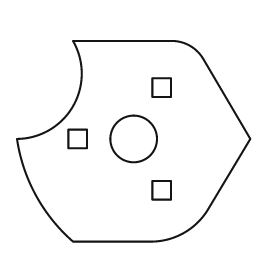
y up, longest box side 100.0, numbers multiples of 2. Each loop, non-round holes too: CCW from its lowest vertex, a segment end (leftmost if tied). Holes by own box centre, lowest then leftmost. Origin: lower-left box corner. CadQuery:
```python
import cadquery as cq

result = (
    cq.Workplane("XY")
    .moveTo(24.0, 0.0)
    .lineTo(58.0, 0.0)
    .threePointArc((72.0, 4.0), (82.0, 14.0))
    .lineTo(100.0, 44.0)
    .lineTo(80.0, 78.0)
    .threePointArc((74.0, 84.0), (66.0, 86.0))
    .lineTo(24.0, 86.0)
    .threePointArc((24.0, 58.0), (0.0, 44.0))
    .threePointArc((8.0, 20.0), (24.0, 0.0))
    .close()
    .moveTo(58.0, 18.0)
    .lineTo(66.0, 18.0)
    .lineTo(66.0, 26.0)
    .lineTo(58.0, 26.0)
    .close()
    .moveTo(22.0, 40.0)
    .lineTo(30.0, 40.0)
    .lineTo(30.0, 48.0)
    .lineTo(22.0, 48.0)
    .close()
    .moveTo(50.0, 44.0)
    .circle(10.0)
    .moveTo(58.0, 62.0)
    .lineTo(66.0, 62.0)
    .lineTo(66.0, 70.0)
    .lineTo(58.0, 70.0)
    .close()
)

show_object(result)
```